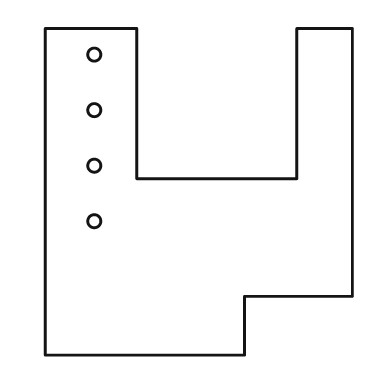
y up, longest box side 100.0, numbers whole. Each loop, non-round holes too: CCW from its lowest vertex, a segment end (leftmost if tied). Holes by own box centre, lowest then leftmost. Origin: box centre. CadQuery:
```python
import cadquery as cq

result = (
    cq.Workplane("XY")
    .moveTo(-47.0, -50.0)
    .lineTo(14.0, -50.0)
    .lineTo(14.0, -32.0)
    .lineTo(47.0, -32.0)
    .lineTo(47.0, 50.0)
    .lineTo(30.0, 50.0)
    .lineTo(30.0, 4.0)
    .lineTo(-19.0, 4.0)
    .lineTo(-19.0, 50.0)
    .lineTo(-47.0, 50.0)
    .close()
    .moveTo(-32.0, -9.0)
    .circle(2.0)
    .moveTo(-32.0, 8.0)
    .circle(2.0)
    .moveTo(-32.0, 25.0)
    .circle(2.0)
    .moveTo(-32.0, 42.0)
    .circle(2.0)
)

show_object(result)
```